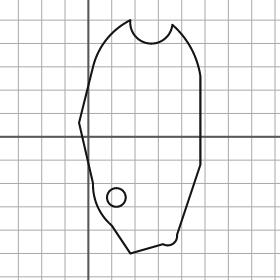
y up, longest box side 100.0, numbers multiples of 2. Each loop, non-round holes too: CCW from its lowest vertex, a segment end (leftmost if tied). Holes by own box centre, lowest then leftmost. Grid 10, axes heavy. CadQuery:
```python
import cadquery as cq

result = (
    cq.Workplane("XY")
    .moveTo(18.0, -50.0)
    .lineTo(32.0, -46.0)
    .threePointArc((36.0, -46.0), (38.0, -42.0))
    .lineTo(48.0, -12.0)
    .lineTo(48.0, 26.0)
    .threePointArc((44.0, 38.0), (36.0, 48.0))
    .threePointArc((26.0, 40.0), (18.0, 50.0))
    .threePointArc((8.0, 42.0), (2.0, 30.0))
    .lineTo(-4.0, 6.0)
    .lineTo(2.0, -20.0)
    .threePointArc((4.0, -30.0), (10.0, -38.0))
    .close()
    .moveTo(12.0, -26.0)
    .circle(4.0)
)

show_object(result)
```